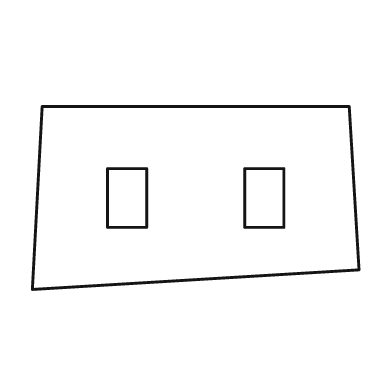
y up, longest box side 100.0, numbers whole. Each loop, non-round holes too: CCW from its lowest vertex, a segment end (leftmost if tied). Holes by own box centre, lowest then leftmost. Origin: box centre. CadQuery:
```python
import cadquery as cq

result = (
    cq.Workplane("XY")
    .moveTo(-50.0, -28.0)
    .lineTo(50.0, -22.0)
    .lineTo(47.0, 28.0)
    .lineTo(-47.0, 28.0)
    .close()
    .moveTo(-27.0, -9.0)
    .lineTo(-15.0, -9.0)
    .lineTo(-15.0, 9.0)
    .lineTo(-27.0, 9.0)
    .close()
    .moveTo(15.0, -9.0)
    .lineTo(27.0, -9.0)
    .lineTo(27.0, 9.0)
    .lineTo(15.0, 9.0)
    .close()
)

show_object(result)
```